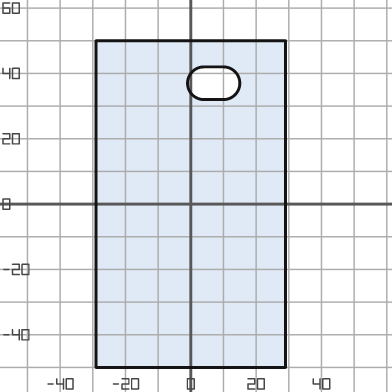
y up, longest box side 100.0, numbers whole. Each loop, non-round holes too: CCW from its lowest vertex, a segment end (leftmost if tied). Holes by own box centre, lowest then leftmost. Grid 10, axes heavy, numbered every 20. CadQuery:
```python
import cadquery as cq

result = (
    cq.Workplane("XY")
    .moveTo(-29.0, -50.0)
    .lineTo(29.0, -50.0)
    .lineTo(29.0, 50.0)
    .lineTo(-29.0, 50.0)
    .close()
    .moveTo(4.0, 32.0)
    .lineTo(10.0, 32.0)
    .threePointArc((15.0, 37.0), (10.0, 42.0))
    .lineTo(4.0, 42.0)
    .threePointArc((-1.0, 37.0), (4.0, 32.0))
    .close()
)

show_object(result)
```